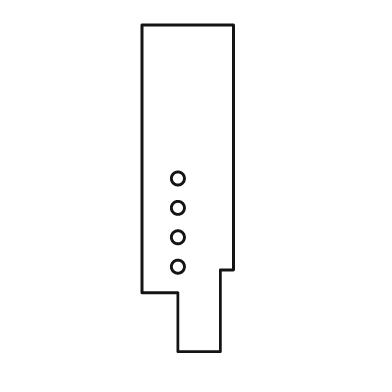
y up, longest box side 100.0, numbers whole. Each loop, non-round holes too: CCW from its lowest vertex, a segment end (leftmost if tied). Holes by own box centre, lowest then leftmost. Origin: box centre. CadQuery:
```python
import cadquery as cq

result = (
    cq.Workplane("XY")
    .moveTo(-3.0, -50.0)
    .lineTo(10.0, -50.0)
    .lineTo(10.0, -25.0)
    .lineTo(14.0, -25.0)
    .lineTo(14.0, 50.0)
    .lineTo(-14.0, 50.0)
    .lineTo(-14.0, -32.0)
    .lineTo(-3.0, -32.0)
    .close()
    .moveTo(-3.0, -24.0)
    .circle(2.0)
    .moveTo(-3.0, -15.0)
    .circle(2.0)
    .moveTo(-3.0, -6.0)
    .circle(2.0)
    .moveTo(-3.0, 3.0)
    .circle(2.0)
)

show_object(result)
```